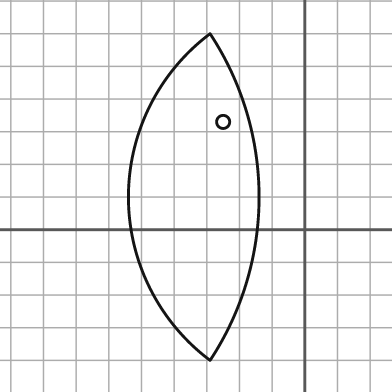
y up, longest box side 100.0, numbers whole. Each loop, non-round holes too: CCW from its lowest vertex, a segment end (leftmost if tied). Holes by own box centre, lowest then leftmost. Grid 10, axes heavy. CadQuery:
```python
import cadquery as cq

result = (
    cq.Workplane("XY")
    .moveTo(-29.0, -40.0)
    .threePointArc((-14.0, 10.0), (-29.0, 60.0))
    .threePointArc((-54.0, 10.0), (-29.0, -40.0))
    .close()
    .moveTo(-25.0, 33.0)
    .circle(2.0)
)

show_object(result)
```